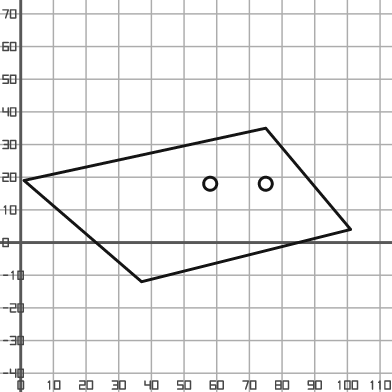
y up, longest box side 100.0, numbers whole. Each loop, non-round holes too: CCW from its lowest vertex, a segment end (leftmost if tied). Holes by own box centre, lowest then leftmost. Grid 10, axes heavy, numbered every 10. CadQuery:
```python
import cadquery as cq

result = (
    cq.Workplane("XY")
    .moveTo(37.0, -12.0)
    .lineTo(101.0, 4.0)
    .lineTo(75.0, 35.0)
    .lineTo(1.0, 19.0)
    .close()
    .moveTo(58.0, 18.0)
    .circle(2.0)
    .moveTo(75.0, 18.0)
    .circle(2.0)
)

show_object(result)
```